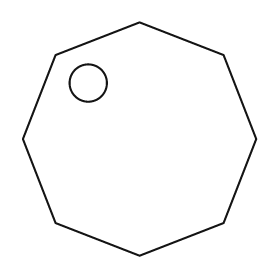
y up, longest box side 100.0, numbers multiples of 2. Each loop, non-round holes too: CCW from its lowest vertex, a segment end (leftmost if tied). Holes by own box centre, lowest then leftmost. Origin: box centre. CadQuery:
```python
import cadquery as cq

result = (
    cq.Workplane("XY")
    .moveTo(0.0, -50.0)
    .lineTo(36.0, -36.0)
    .lineTo(50.0, 0.0)
    .lineTo(36.0, 36.0)
    .lineTo(0.0, 50.0)
    .lineTo(-36.0, 36.0)
    .lineTo(-50.0, 0.0)
    .lineTo(-36.0, -36.0)
    .close()
    .moveTo(-22.0, 24.0)
    .circle(8.0)
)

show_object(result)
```